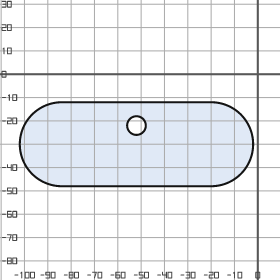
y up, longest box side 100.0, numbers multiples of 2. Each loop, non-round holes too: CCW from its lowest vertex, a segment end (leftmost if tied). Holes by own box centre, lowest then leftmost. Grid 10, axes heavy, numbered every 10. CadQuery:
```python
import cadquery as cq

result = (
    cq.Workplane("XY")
    .moveTo(-84.0, -48.0)
    .lineTo(-20.0, -48.0)
    .threePointArc((-2.0, -30.0), (-20.0, -12.0))
    .lineTo(-84.0, -12.0)
    .threePointArc((-102.0, -30.0), (-84.0, -48.0))
    .close()
    .moveTo(-52.0, -22.0)
    .circle(4.0)
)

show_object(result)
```